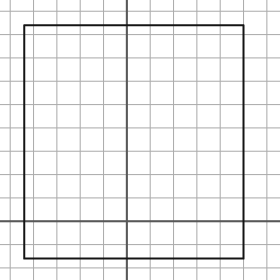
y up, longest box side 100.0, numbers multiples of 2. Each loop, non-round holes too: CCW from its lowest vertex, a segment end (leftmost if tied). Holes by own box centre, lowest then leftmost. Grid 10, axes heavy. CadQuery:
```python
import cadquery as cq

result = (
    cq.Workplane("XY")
    .moveTo(-44.0, -16.0)
    .lineTo(50.0, -16.0)
    .lineTo(50.0, 84.0)
    .lineTo(-44.0, 84.0)
    .close()
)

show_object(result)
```